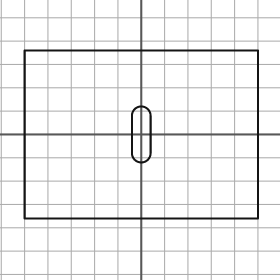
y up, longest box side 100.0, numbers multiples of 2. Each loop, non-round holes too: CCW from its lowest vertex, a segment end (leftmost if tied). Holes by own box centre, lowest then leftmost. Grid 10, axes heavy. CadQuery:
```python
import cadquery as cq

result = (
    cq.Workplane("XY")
    .moveTo(-50.0, -36.0)
    .lineTo(50.0, -36.0)
    .lineTo(50.0, 36.0)
    .lineTo(-50.0, 36.0)
    .close()
    .moveTo(-4.0, -8.0)
    .threePointArc((0.0, -12.0), (4.0, -8.0))
    .lineTo(4.0, 8.0)
    .threePointArc((0.0, 12.0), (-4.0, 8.0))
    .close()
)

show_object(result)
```